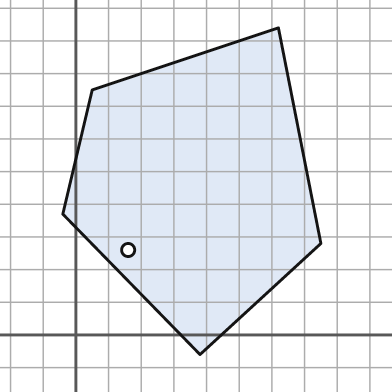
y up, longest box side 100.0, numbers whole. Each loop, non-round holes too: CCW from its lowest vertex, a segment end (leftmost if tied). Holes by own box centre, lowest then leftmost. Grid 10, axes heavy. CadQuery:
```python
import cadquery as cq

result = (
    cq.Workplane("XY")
    .moveTo(38.0, -6.0)
    .lineTo(75.0, 28.0)
    .lineTo(62.0, 94.0)
    .lineTo(5.0, 75.0)
    .lineTo(-4.0, 37.0)
    .close()
    .moveTo(16.0, 26.0)
    .circle(2.0)
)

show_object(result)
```